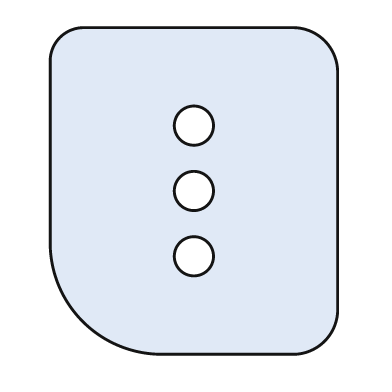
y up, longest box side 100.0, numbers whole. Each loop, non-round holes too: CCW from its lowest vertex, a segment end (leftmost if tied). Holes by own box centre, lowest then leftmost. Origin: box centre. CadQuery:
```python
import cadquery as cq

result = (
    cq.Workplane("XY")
    .moveTo(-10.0, -50.0)
    .lineTo(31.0, -50.0)
    .threePointArc((40.0, -46.0), (44.0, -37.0))
    .lineTo(44.0, 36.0)
    .threePointArc((40.0, 46.0), (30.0, 50.0))
    .lineTo(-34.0, 50.0)
    .threePointArc((-41.0, 47.0), (-44.0, 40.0))
    .lineTo(-44.0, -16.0)
    .threePointArc((-34.0, -40.0), (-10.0, -50.0))
    .close()
    .moveTo(0.0, -20.0)
    .circle(6.0)
    .moveTo(0.0, 0.0)
    .circle(6.0)
    .moveTo(0.0, 20.0)
    .circle(6.0)
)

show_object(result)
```